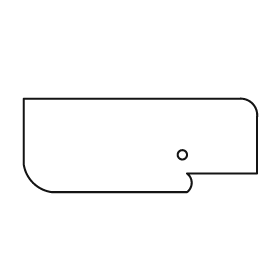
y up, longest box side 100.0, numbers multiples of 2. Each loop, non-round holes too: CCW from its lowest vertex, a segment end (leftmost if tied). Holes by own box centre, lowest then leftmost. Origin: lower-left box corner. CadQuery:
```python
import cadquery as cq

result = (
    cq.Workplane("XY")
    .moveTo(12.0, 0.0)
    .lineTo(70.0, 0.0)
    .threePointArc((72.0, 4.0), (70.0, 8.0))
    .lineTo(100.0, 8.0)
    .lineTo(100.0, 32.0)
    .threePointArc((98.0, 38.0), (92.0, 40.0))
    .lineTo(0.0, 40.0)
    .lineTo(0.0, 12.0)
    .threePointArc((4.0, 4.0), (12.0, 0.0))
    .close()
    .moveTo(68.0, 16.0)
    .circle(2.0)
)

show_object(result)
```